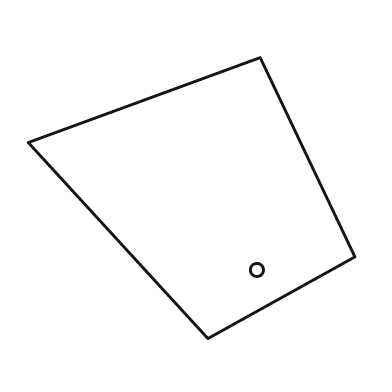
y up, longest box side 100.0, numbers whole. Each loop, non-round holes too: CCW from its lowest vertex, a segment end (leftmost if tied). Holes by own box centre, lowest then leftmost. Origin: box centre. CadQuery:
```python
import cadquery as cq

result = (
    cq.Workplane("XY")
    .moveTo(5.0, -43.0)
    .lineTo(50.0, -18.0)
    .lineTo(21.0, 43.0)
    .lineTo(-50.0, 17.0)
    .close()
    .moveTo(20.0, -22.0)
    .circle(2.0)
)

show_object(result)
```